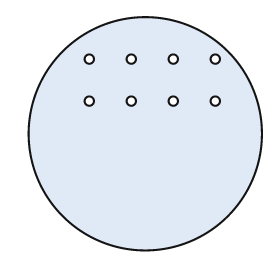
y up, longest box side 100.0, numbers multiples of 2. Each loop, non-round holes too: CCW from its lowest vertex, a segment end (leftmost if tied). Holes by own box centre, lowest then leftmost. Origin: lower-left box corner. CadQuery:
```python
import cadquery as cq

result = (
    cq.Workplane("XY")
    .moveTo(50.0, 50.0)
    .circle(50.0)
    .moveTo(26.0, 64.0)
    .circle(2.0)
    .moveTo(44.0, 64.0)
    .circle(2.0)
    .moveTo(62.0, 64.0)
    .circle(2.0)
    .moveTo(80.0, 64.0)
    .circle(2.0)
    .moveTo(26.0, 82.0)
    .circle(2.0)
    .moveTo(44.0, 82.0)
    .circle(2.0)
    .moveTo(62.0, 82.0)
    .circle(2.0)
    .moveTo(80.0, 82.0)
    .circle(2.0)
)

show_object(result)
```